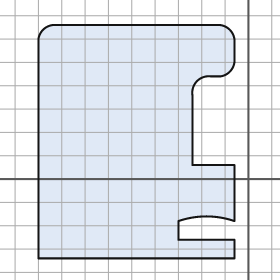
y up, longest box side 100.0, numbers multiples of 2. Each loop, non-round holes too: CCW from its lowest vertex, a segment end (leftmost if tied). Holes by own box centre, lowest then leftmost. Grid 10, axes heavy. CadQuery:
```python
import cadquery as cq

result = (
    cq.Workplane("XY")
    .moveTo(-90.0, -34.0)
    .lineTo(-6.0, -34.0)
    .lineTo(-6.0, -26.0)
    .lineTo(-30.0, -26.0)
    .lineTo(-30.0, -18.0)
    .threePointArc((-18.0, -16.0), (-6.0, -18.0))
    .lineTo(-6.0, 6.0)
    .lineTo(-24.0, 6.0)
    .lineTo(-24.0, 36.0)
    .threePointArc((-22.0, 42.0), (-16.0, 44.0))
    .lineTo(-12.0, 44.0)
    .threePointArc((-8.0, 46.0), (-6.0, 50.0))
    .lineTo(-6.0, 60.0)
    .threePointArc((-8.0, 64.0), (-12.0, 66.0))
    .lineTo(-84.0, 66.0)
    .threePointArc((-88.0, 64.0), (-90.0, 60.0))
    .close()
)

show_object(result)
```